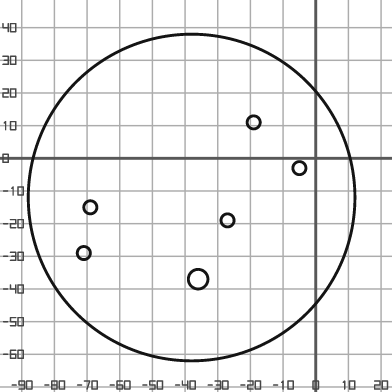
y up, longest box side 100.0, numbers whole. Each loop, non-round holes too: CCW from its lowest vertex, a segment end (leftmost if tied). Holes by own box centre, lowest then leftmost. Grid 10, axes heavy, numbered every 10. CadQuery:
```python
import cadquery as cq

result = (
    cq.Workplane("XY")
    .moveTo(-38.0, -12.0)
    .circle(50.0)
    .moveTo(-36.0, -37.0)
    .circle(3.0)
    .moveTo(-71.0, -29.0)
    .circle(2.0)
    .moveTo(-27.0, -19.0)
    .circle(2.0)
    .moveTo(-69.0, -15.0)
    .circle(2.0)
    .moveTo(-5.0, -3.0)
    .circle(2.0)
    .moveTo(-19.0, 11.0)
    .circle(2.0)
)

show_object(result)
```